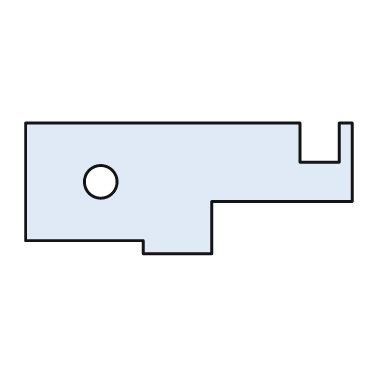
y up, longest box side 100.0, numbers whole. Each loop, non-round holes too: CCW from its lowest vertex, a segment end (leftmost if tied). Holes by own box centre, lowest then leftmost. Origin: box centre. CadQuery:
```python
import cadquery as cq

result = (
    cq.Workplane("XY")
    .moveTo(-14.0, -20.0)
    .lineTo(7.0, -20.0)
    .lineTo(7.0, -4.0)
    .lineTo(50.0, -4.0)
    .lineTo(50.0, 20.0)
    .lineTo(46.0, 20.0)
    .lineTo(46.0, 8.0)
    .lineTo(34.0, 8.0)
    .lineTo(34.0, 20.0)
    .lineTo(-50.0, 20.0)
    .lineTo(-50.0, -16.0)
    .lineTo(-14.0, -16.0)
    .close()
    .moveTo(-27.0, 2.0)
    .circle(5.0)
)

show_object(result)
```